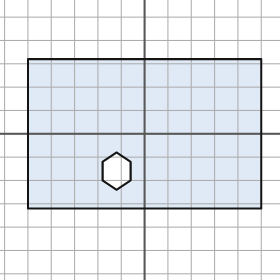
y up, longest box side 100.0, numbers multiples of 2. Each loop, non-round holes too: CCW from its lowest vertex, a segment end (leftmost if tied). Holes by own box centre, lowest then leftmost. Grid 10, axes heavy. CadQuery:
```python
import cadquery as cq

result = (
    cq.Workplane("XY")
    .moveTo(-50.0, -32.0)
    .lineTo(50.0, -32.0)
    .lineTo(50.0, 32.0)
    .lineTo(-50.0, 32.0)
    .close()
    .moveTo(-12.0, -24.0)
    .lineTo(-6.0, -20.0)
    .lineTo(-6.0, -12.0)
    .lineTo(-12.0, -8.0)
    .lineTo(-18.0, -12.0)
    .lineTo(-18.0, -20.0)
    .close()
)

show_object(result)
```